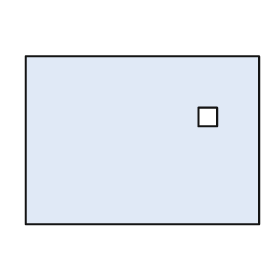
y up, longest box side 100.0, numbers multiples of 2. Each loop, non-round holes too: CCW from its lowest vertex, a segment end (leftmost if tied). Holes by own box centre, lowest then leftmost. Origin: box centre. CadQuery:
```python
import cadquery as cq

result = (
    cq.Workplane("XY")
    .moveTo(-50.0, -36.0)
    .lineTo(50.0, -36.0)
    .lineTo(50.0, 36.0)
    .lineTo(-50.0, 36.0)
    .close()
    .moveTo(24.0, 6.0)
    .lineTo(32.0, 6.0)
    .lineTo(32.0, 14.0)
    .lineTo(24.0, 14.0)
    .close()
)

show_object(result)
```